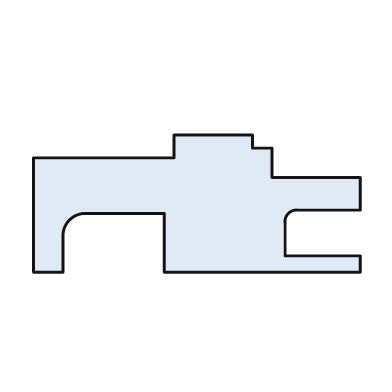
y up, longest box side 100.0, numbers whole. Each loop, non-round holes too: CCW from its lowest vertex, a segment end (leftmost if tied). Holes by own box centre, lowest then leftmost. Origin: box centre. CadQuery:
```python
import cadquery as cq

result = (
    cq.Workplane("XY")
    .moveTo(-50.0, -21.0)
    .lineTo(-41.0, -21.0)
    .lineTo(-41.0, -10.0)
    .threePointArc((-39.0, -5.0), (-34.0, -3.0))
    .lineTo(-10.0, -3.0)
    .lineTo(-10.0, -21.0)
    .lineTo(50.0, -21.0)
    .lineTo(50.0, -16.0)
    .lineTo(27.0, -16.0)
    .lineTo(27.0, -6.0)
    .threePointArc((28.0, -3.0), (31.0, -2.0))
    .lineTo(50.0, -2.0)
    .lineTo(50.0, 8.0)
    .lineTo(23.0, 8.0)
    .lineTo(23.0, 17.0)
    .lineTo(17.0, 17.0)
    .lineTo(17.0, 21.0)
    .lineTo(-7.0, 21.0)
    .lineTo(-7.0, 14.0)
    .lineTo(-50.0, 14.0)
    .close()
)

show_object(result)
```